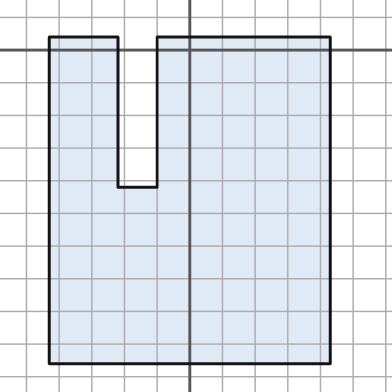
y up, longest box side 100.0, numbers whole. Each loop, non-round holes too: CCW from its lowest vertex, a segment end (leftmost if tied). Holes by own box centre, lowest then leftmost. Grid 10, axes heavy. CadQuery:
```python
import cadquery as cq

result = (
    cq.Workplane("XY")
    .moveTo(-43.0, -96.0)
    .lineTo(43.0, -96.0)
    .lineTo(43.0, 4.0)
    .lineTo(-10.0, 4.0)
    .lineTo(-10.0, -42.0)
    .lineTo(-22.0, -42.0)
    .lineTo(-22.0, 4.0)
    .lineTo(-43.0, 4.0)
    .close()
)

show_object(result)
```